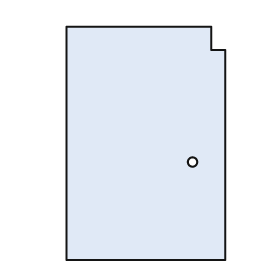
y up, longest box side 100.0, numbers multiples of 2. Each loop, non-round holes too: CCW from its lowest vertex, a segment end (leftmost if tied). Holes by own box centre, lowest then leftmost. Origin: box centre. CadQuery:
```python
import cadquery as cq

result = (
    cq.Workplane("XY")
    .moveTo(-34.0, -50.0)
    .lineTo(34.0, -50.0)
    .lineTo(34.0, 40.0)
    .lineTo(28.0, 40.0)
    .lineTo(28.0, 50.0)
    .lineTo(-34.0, 50.0)
    .close()
    .moveTo(20.0, -8.0)
    .circle(2.0)
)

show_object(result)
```